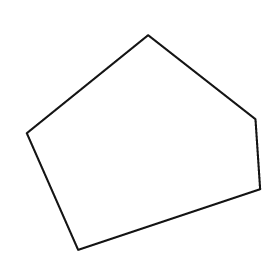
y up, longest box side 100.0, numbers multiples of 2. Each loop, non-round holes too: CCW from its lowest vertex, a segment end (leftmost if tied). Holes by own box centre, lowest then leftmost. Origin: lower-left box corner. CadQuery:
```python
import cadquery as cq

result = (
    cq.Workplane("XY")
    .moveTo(22.0, 0.0)
    .lineTo(100.0, 26.0)
    .lineTo(98.0, 56.0)
    .lineTo(52.0, 92.0)
    .lineTo(0.0, 50.0)
    .close()
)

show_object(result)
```